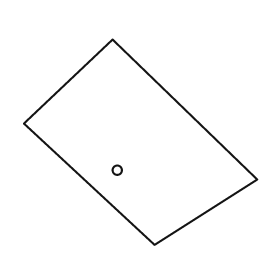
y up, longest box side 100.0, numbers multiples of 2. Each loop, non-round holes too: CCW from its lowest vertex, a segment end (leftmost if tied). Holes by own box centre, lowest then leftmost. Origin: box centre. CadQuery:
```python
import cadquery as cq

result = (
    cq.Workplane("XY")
    .moveTo(6.0, -44.0)
    .lineTo(50.0, -16.0)
    .lineTo(-12.0, 44.0)
    .lineTo(-50.0, 8.0)
    .close()
    .moveTo(-10.0, -12.0)
    .circle(2.0)
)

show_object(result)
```